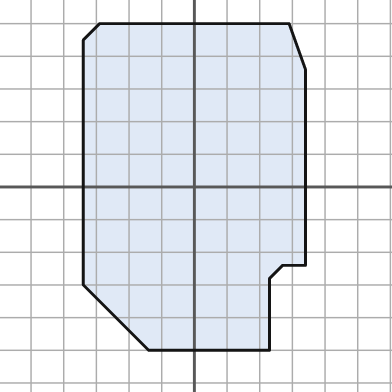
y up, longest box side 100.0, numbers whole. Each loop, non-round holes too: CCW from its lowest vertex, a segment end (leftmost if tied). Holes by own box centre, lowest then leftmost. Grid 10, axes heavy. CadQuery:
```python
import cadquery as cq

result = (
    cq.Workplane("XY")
    .moveTo(-14.0, -50.0)
    .lineTo(23.0, -50.0)
    .lineTo(23.0, -28.0)
    .lineTo(27.0, -24.0)
    .lineTo(34.0, -24.0)
    .lineTo(34.0, 36.0)
    .lineTo(29.0, 50.0)
    .lineTo(-29.0, 50.0)
    .lineTo(-34.0, 45.0)
    .lineTo(-34.0, -30.0)
    .close()
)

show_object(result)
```